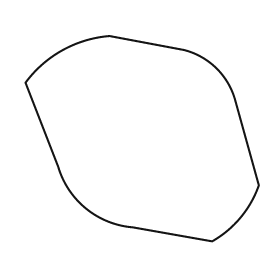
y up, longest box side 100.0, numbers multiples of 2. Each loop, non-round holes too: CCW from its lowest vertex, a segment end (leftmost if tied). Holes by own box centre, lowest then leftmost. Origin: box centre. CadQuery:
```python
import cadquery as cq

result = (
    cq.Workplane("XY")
    .moveTo(30.0, -44.0)
    .threePointArc((42.0, -34.0), (50.0, -20.0))
    .lineTo(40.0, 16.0)
    .threePointArc((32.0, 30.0), (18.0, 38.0))
    .lineTo(-14.0, 44.0)
    .threePointArc((-34.0, 38.0), (-50.0, 24.0))
    .lineTo(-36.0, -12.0)
    .threePointArc((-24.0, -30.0), (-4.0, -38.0))
    .close()
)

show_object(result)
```